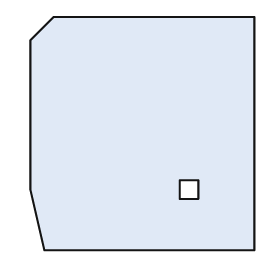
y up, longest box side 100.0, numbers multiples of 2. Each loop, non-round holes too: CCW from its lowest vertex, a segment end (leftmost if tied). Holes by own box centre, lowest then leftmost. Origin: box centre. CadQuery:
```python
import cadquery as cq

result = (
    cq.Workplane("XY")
    .moveTo(-42.0, -50.0)
    .lineTo(48.0, -50.0)
    .lineTo(48.0, 50.0)
    .lineTo(-38.0, 50.0)
    .lineTo(-48.0, 40.0)
    .lineTo(-48.0, -24.0)
    .close()
    .moveTo(16.0, -28.0)
    .lineTo(24.0, -28.0)
    .lineTo(24.0, -20.0)
    .lineTo(16.0, -20.0)
    .close()
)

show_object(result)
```